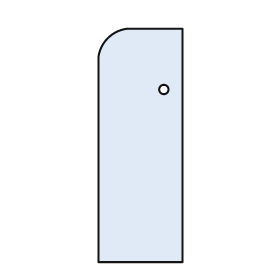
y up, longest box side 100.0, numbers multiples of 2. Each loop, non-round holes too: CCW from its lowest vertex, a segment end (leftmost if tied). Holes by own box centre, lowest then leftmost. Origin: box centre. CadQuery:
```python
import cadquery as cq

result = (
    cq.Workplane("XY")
    .moveTo(-18.0, -50.0)
    .lineTo(18.0, -50.0)
    .lineTo(18.0, 50.0)
    .lineTo(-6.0, 50.0)
    .threePointArc((-14.0, 46.0), (-18.0, 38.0))
    .close()
    .moveTo(10.0, 24.0)
    .circle(2.0)
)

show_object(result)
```